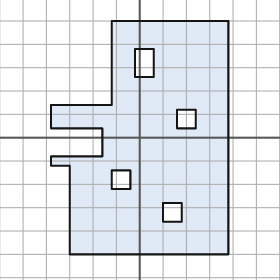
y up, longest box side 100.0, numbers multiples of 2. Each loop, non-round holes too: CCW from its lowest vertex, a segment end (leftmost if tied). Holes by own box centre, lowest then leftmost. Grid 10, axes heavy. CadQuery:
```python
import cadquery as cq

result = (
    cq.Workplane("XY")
    .moveTo(-30.0, -50.0)
    .lineTo(38.0, -50.0)
    .lineTo(38.0, 50.0)
    .lineTo(-12.0, 50.0)
    .lineTo(-12.0, 14.0)
    .lineTo(-38.0, 14.0)
    .lineTo(-38.0, 4.0)
    .lineTo(-16.0, 4.0)
    .lineTo(-16.0, -8.0)
    .lineTo(-38.0, -8.0)
    .lineTo(-38.0, -12.0)
    .lineTo(-30.0, -12.0)
    .close()
    .moveTo(10.0, -36.0)
    .lineTo(18.0, -36.0)
    .lineTo(18.0, -28.0)
    .lineTo(10.0, -28.0)
    .close()
    .moveTo(-12.0, -22.0)
    .lineTo(-4.0, -22.0)
    .lineTo(-4.0, -14.0)
    .lineTo(-12.0, -14.0)
    .close()
    .moveTo(16.0, 4.0)
    .lineTo(24.0, 4.0)
    .lineTo(24.0, 12.0)
    .lineTo(16.0, 12.0)
    .close()
    .moveTo(-2.0, 26.0)
    .lineTo(6.0, 26.0)
    .lineTo(6.0, 38.0)
    .lineTo(-2.0, 38.0)
    .close()
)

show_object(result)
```